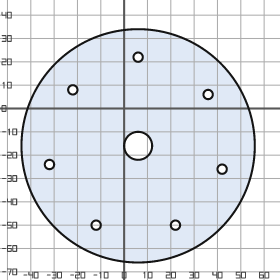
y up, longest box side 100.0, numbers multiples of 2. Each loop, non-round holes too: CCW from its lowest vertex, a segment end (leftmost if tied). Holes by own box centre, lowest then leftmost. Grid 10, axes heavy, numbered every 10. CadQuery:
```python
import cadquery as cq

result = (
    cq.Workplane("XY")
    .moveTo(6.0, -16.0)
    .circle(50.0)
    .moveTo(-12.0, -50.0)
    .circle(2.0)
    .moveTo(22.0, -50.0)
    .circle(2.0)
    .moveTo(42.0, -26.0)
    .circle(2.0)
    .moveTo(-32.0, -24.0)
    .circle(2.0)
    .moveTo(6.0, -16.0)
    .circle(6.0)
    .moveTo(36.0, 6.0)
    .circle(2.0)
    .moveTo(-22.0, 8.0)
    .circle(2.0)
    .moveTo(6.0, 22.0)
    .circle(2.0)
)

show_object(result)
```